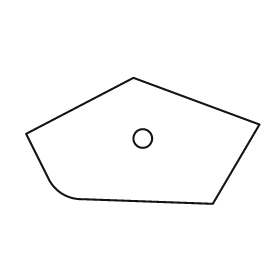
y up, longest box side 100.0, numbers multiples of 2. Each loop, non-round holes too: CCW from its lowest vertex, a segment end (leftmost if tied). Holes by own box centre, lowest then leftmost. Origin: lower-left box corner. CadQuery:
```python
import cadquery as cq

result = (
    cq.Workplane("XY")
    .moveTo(80.0, 0.0)
    .lineTo(100.0, 34.0)
    .lineTo(46.0, 54.0)
    .lineTo(0.0, 30.0)
    .lineTo(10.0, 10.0)
    .threePointArc((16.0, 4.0), (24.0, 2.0))
    .close()
    .moveTo(50.0, 28.0)
    .circle(4.0)
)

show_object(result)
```